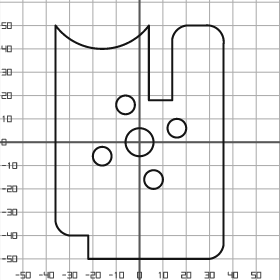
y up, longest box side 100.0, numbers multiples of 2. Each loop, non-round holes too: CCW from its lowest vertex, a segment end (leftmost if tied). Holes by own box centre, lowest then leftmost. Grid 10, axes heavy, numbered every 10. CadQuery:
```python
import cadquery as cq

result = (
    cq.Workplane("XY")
    .moveTo(-22.0, -50.0)
    .lineTo(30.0, -50.0)
    .threePointArc((34.0, -48.0), (36.0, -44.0))
    .lineTo(36.0, 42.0)
    .threePointArc((34.0, 48.0), (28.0, 50.0))
    .lineTo(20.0, 50.0)
    .threePointArc((16.0, 48.0), (14.0, 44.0))
    .lineTo(14.0, 18.0)
    .lineTo(4.0, 18.0)
    .lineTo(4.0, 50.0)
    .threePointArc((-16.0, 40.0), (-36.0, 50.0))
    .lineTo(-36.0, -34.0)
    .threePointArc((-34.0, -38.0), (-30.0, -40.0))
    .lineTo(-22.0, -40.0)
    .close()
    .moveTo(6.0, -16.0)
    .circle(4.0)
    .moveTo(-16.0, -6.0)
    .circle(4.0)
    .moveTo(0.0, 0.0)
    .circle(6.0)
    .moveTo(16.0, 6.0)
    .circle(4.0)
    .moveTo(-6.0, 16.0)
    .circle(4.0)
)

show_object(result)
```